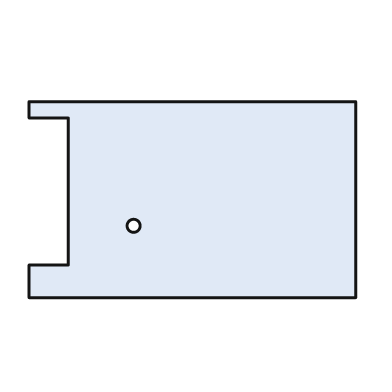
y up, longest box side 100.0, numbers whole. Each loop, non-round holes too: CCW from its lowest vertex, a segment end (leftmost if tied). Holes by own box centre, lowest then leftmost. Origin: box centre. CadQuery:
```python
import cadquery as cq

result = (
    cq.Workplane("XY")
    .moveTo(-50.0, -30.0)
    .lineTo(50.0, -30.0)
    .lineTo(50.0, 30.0)
    .lineTo(-50.0, 30.0)
    .lineTo(-50.0, 25.0)
    .lineTo(-38.0, 25.0)
    .lineTo(-38.0, -20.0)
    .lineTo(-50.0, -20.0)
    .close()
    .moveTo(-18.0, -8.0)
    .circle(2.0)
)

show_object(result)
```